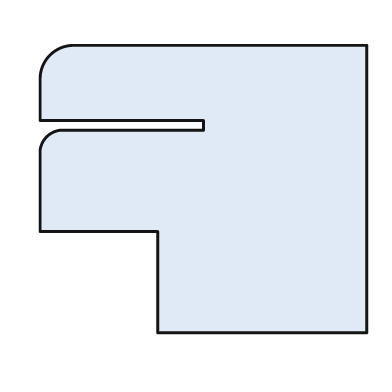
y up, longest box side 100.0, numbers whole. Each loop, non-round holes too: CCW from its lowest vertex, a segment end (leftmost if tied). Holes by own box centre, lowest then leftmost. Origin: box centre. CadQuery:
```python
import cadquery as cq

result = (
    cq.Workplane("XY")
    .moveTo(-14.0, -44.0)
    .lineTo(50.0, -44.0)
    .lineTo(50.0, 44.0)
    .lineTo(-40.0, 44.0)
    .threePointArc((-47.0, 41.0), (-50.0, 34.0))
    .lineTo(-50.0, 21.0)
    .lineTo(0.0, 21.0)
    .lineTo(0.0, 18.0)
    .lineTo(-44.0, 18.0)
    .threePointArc((-48.0, 16.0), (-50.0, 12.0))
    .lineTo(-50.0, -13.0)
    .lineTo(-14.0, -13.0)
    .close()
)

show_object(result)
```